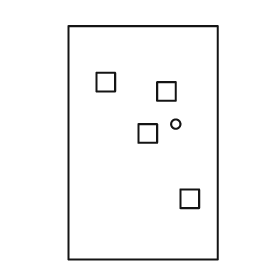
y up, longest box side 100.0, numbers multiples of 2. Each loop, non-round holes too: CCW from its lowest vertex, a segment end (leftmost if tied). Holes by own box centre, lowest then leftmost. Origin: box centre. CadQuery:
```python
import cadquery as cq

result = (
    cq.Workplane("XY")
    .moveTo(-32.0, -50.0)
    .lineTo(32.0, -50.0)
    .lineTo(32.0, 50.0)
    .lineTo(-32.0, 50.0)
    .close()
    .moveTo(16.0, -28.0)
    .lineTo(24.0, -28.0)
    .lineTo(24.0, -20.0)
    .lineTo(16.0, -20.0)
    .close()
    .moveTo(-2.0, 0.0)
    .lineTo(6.0, 0.0)
    .lineTo(6.0, 8.0)
    .lineTo(-2.0, 8.0)
    .close()
    .moveTo(14.0, 8.0)
    .circle(2.0)
    .moveTo(6.0, 18.0)
    .lineTo(14.0, 18.0)
    .lineTo(14.0, 26.0)
    .lineTo(6.0, 26.0)
    .close()
    .moveTo(-20.0, 22.0)
    .lineTo(-12.0, 22.0)
    .lineTo(-12.0, 30.0)
    .lineTo(-20.0, 30.0)
    .close()
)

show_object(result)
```